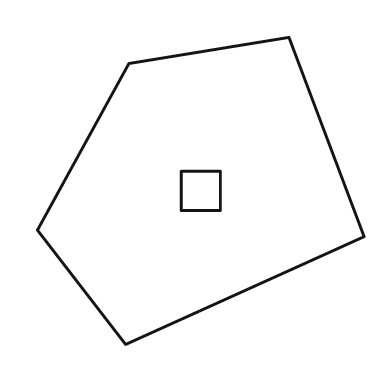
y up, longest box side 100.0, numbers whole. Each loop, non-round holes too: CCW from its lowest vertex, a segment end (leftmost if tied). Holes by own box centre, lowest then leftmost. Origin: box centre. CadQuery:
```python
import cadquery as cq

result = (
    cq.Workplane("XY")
    .moveTo(-23.0, -47.0)
    .lineTo(50.0, -14.0)
    .lineTo(27.0, 47.0)
    .lineTo(-22.0, 39.0)
    .lineTo(-50.0, -12.0)
    .close()
    .moveTo(-6.0, -6.0)
    .lineTo(6.0, -6.0)
    .lineTo(6.0, 6.0)
    .lineTo(-6.0, 6.0)
    .close()
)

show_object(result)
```